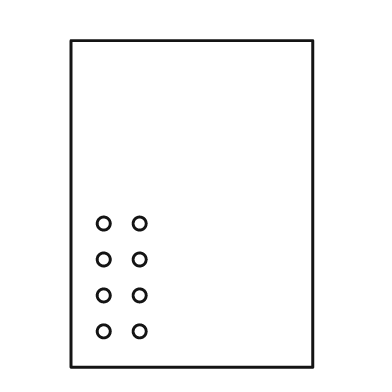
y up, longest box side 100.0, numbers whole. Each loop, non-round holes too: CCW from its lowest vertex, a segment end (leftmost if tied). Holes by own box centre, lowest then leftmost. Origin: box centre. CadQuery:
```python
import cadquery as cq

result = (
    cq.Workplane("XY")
    .moveTo(-37.0, -50.0)
    .lineTo(37.0, -50.0)
    .lineTo(37.0, 50.0)
    .lineTo(-37.0, 50.0)
    .close()
    .moveTo(-27.0, -39.0)
    .circle(2.0)
    .moveTo(-16.0, -39.0)
    .circle(2.0)
    .moveTo(-27.0, -28.0)
    .circle(2.0)
    .moveTo(-16.0, -28.0)
    .circle(2.0)
    .moveTo(-27.0, -17.0)
    .circle(2.0)
    .moveTo(-16.0, -17.0)
    .circle(2.0)
    .moveTo(-27.0, -6.0)
    .circle(2.0)
    .moveTo(-16.0, -6.0)
    .circle(2.0)
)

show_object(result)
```